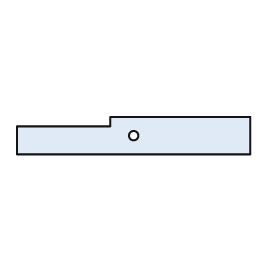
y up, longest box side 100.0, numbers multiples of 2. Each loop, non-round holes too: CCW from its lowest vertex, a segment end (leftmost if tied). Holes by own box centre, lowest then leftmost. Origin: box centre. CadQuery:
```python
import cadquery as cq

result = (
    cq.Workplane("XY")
    .moveTo(-50.0, -8.0)
    .lineTo(50.0, -8.0)
    .lineTo(50.0, 8.0)
    .lineTo(-10.0, 8.0)
    .lineTo(-10.0, 4.0)
    .lineTo(-50.0, 4.0)
    .close()
    .moveTo(0.0, 0.0)
    .circle(2.0)
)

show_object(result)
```